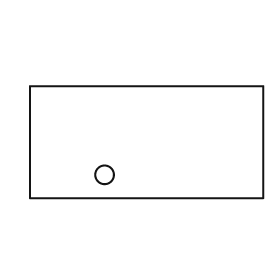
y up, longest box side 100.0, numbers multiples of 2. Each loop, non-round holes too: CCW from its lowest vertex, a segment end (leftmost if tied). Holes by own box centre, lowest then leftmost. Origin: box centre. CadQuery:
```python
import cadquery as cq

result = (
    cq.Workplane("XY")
    .moveTo(-50.0, -24.0)
    .lineTo(50.0, -24.0)
    .lineTo(50.0, 24.0)
    .lineTo(-50.0, 24.0)
    .close()
    .moveTo(-18.0, -14.0)
    .circle(4.0)
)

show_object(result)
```